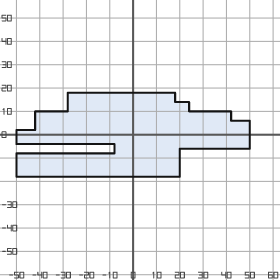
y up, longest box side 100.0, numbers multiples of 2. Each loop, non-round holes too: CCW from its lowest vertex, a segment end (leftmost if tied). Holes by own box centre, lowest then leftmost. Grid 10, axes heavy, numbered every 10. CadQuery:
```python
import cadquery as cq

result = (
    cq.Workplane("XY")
    .moveTo(-50.0, -18.0)
    .lineTo(20.0, -18.0)
    .lineTo(20.0, -6.0)
    .lineTo(50.0, -6.0)
    .lineTo(50.0, 6.0)
    .lineTo(42.0, 6.0)
    .lineTo(42.0, 10.0)
    .lineTo(24.0, 10.0)
    .lineTo(24.0, 14.0)
    .lineTo(18.0, 14.0)
    .lineTo(18.0, 18.0)
    .lineTo(-28.0, 18.0)
    .lineTo(-28.0, 10.0)
    .lineTo(-42.0, 10.0)
    .lineTo(-42.0, 2.0)
    .lineTo(-50.0, 2.0)
    .lineTo(-50.0, -4.0)
    .lineTo(-8.0, -4.0)
    .lineTo(-8.0, -8.0)
    .lineTo(-50.0, -8.0)
    .close()
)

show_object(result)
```